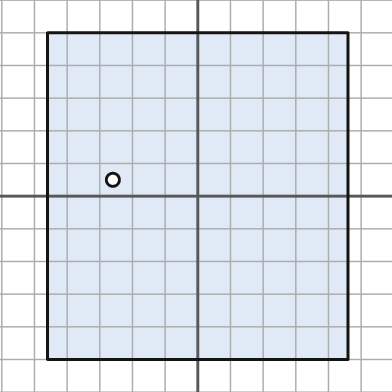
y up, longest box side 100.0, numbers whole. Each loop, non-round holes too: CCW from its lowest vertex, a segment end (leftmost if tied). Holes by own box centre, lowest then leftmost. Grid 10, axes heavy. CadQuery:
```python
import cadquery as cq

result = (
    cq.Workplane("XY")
    .moveTo(-46.0, -50.0)
    .lineTo(46.0, -50.0)
    .lineTo(46.0, 50.0)
    .lineTo(-46.0, 50.0)
    .close()
    .moveTo(-26.0, 5.0)
    .circle(2.0)
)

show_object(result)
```